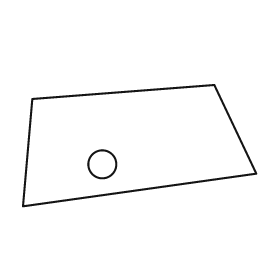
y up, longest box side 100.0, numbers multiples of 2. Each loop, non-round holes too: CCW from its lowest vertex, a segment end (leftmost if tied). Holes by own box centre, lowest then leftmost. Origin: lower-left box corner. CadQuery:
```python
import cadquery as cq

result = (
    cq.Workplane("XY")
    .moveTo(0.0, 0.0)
    .lineTo(100.0, 14.0)
    .lineTo(82.0, 52.0)
    .lineTo(4.0, 46.0)
    .close()
    .moveTo(34.0, 18.0)
    .circle(6.0)
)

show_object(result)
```